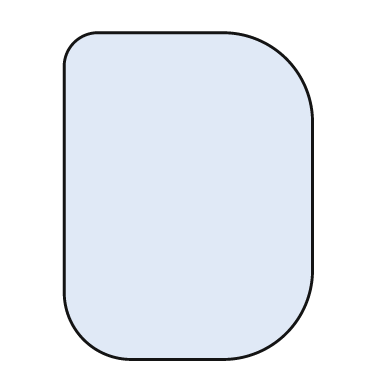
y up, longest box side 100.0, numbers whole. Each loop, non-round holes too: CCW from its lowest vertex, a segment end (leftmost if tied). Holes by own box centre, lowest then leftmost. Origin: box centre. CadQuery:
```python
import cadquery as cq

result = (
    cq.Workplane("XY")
    .moveTo(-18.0, -50.0)
    .lineTo(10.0, -50.0)
    .threePointArc((30.0, -42.0), (38.0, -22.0))
    .lineTo(38.0, 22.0)
    .threePointArc((30.0, 42.0), (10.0, 50.0))
    .lineTo(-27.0, 50.0)
    .threePointArc((-35.0, 47.0), (-38.0, 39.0))
    .lineTo(-38.0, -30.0)
    .threePointArc((-32.0, -44.0), (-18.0, -50.0))
    .close()
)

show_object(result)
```